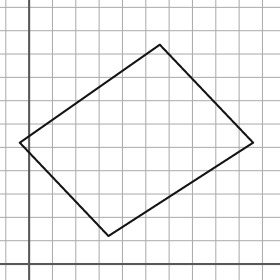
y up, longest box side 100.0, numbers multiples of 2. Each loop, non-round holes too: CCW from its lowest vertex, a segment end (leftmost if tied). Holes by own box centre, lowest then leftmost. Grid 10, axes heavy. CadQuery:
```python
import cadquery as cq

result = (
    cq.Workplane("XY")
    .moveTo(34.0, 12.0)
    .lineTo(96.0, 52.0)
    .lineTo(56.0, 94.0)
    .lineTo(-4.0, 52.0)
    .close()
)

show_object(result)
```